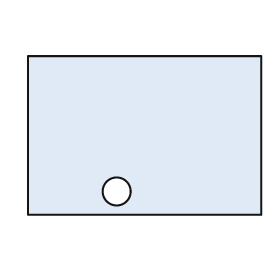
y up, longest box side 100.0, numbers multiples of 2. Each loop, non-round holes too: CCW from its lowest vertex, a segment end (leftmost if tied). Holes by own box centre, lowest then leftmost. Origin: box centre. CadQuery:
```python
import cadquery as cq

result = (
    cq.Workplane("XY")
    .moveTo(-50.0, -34.0)
    .lineTo(50.0, -34.0)
    .lineTo(50.0, 34.0)
    .lineTo(-50.0, 34.0)
    .close()
    .moveTo(-12.0, -24.0)
    .circle(6.0)
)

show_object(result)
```